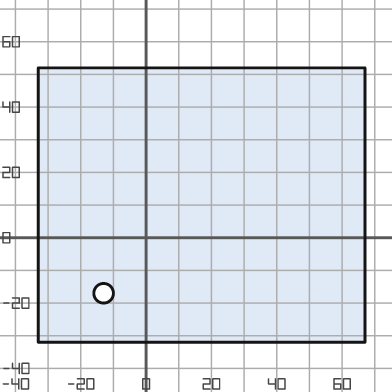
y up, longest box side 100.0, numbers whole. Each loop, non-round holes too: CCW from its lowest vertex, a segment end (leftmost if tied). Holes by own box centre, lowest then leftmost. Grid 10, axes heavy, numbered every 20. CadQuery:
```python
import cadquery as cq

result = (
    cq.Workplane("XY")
    .moveTo(-33.0, -32.0)
    .lineTo(67.0, -32.0)
    .lineTo(67.0, 52.0)
    .lineTo(-33.0, 52.0)
    .close()
    .moveTo(-13.0, -17.0)
    .circle(3.0)
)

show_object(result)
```